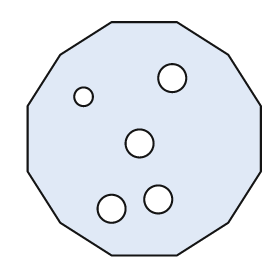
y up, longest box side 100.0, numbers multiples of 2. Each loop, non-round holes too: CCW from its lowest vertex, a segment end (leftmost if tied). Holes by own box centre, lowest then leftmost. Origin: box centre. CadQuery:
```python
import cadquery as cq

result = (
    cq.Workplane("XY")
    .moveTo(-14.0, -50.0)
    .lineTo(14.0, -50.0)
    .lineTo(36.0, -36.0)
    .lineTo(50.0, -14.0)
    .lineTo(50.0, 14.0)
    .lineTo(36.0, 36.0)
    .lineTo(14.0, 50.0)
    .lineTo(-14.0, 50.0)
    .lineTo(-36.0, 36.0)
    .lineTo(-50.0, 14.0)
    .lineTo(-50.0, -14.0)
    .lineTo(-36.0, -36.0)
    .close()
    .moveTo(-14.0, -30.0)
    .circle(6.0)
    .moveTo(6.0, -26.0)
    .circle(6.0)
    .moveTo(-2.0, -2.0)
    .circle(6.0)
    .moveTo(-26.0, 18.0)
    .circle(4.0)
    .moveTo(12.0, 26.0)
    .circle(6.0)
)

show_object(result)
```